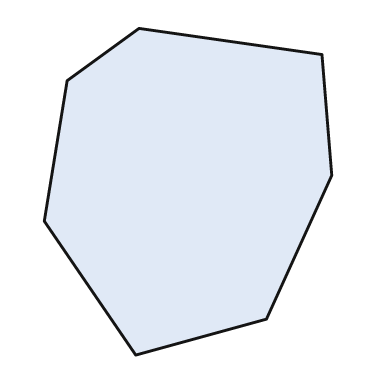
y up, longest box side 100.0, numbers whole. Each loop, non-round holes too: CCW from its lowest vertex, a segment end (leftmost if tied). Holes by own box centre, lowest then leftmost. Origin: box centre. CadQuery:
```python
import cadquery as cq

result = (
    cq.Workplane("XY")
    .moveTo(-16.0, -50.0)
    .lineTo(24.0, -39.0)
    .lineTo(44.0, 5.0)
    .lineTo(41.0, 42.0)
    .lineTo(-15.0, 50.0)
    .lineTo(-37.0, 34.0)
    .lineTo(-44.0, -9.0)
    .close()
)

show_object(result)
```